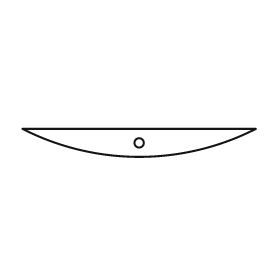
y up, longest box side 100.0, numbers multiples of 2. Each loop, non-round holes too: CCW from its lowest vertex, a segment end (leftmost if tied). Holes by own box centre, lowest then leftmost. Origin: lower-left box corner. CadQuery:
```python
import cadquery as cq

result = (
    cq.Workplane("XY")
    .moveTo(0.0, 12.0)
    .threePointArc((50.0, 0.0), (100.0, 12.0))
    .close()
    .moveTo(50.0, 6.0)
    .circle(2.0)
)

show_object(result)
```